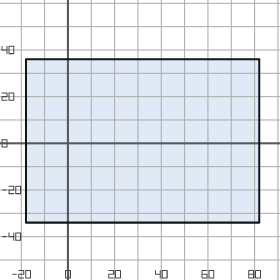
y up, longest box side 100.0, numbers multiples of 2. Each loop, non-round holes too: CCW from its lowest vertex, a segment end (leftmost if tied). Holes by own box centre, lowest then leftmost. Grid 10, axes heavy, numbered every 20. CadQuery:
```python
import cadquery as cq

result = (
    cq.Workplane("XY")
    .moveTo(-18.0, -34.0)
    .lineTo(82.0, -34.0)
    .lineTo(82.0, 36.0)
    .lineTo(-18.0, 36.0)
    .close()
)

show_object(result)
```